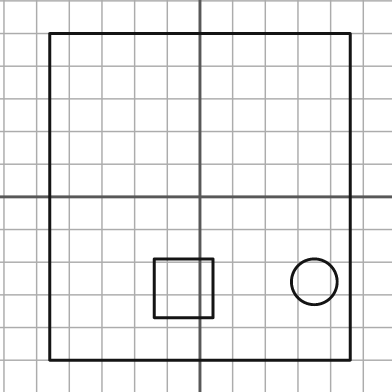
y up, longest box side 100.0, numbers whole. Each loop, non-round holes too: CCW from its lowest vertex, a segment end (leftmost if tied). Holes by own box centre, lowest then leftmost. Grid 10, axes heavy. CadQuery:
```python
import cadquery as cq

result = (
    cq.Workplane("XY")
    .moveTo(-46.0, -50.0)
    .lineTo(46.0, -50.0)
    .lineTo(46.0, 50.0)
    .lineTo(-46.0, 50.0)
    .close()
    .moveTo(-14.0, -37.0)
    .lineTo(4.0, -37.0)
    .lineTo(4.0, -19.0)
    .lineTo(-14.0, -19.0)
    .close()
    .moveTo(35.0, -26.0)
    .circle(7.0)
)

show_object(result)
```